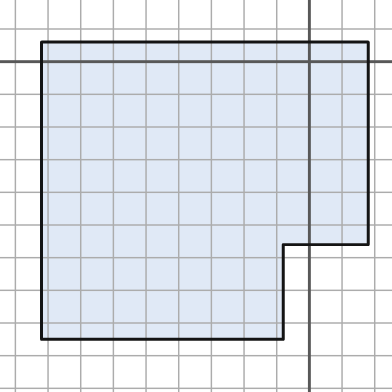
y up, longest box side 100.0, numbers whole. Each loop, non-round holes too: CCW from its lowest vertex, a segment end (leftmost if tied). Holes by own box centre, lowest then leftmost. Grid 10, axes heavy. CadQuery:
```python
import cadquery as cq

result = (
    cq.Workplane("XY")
    .moveTo(-82.0, -85.0)
    .lineTo(-8.0, -85.0)
    .lineTo(-8.0, -56.0)
    .lineTo(18.0, -56.0)
    .lineTo(18.0, 6.0)
    .lineTo(-82.0, 6.0)
    .close()
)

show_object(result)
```